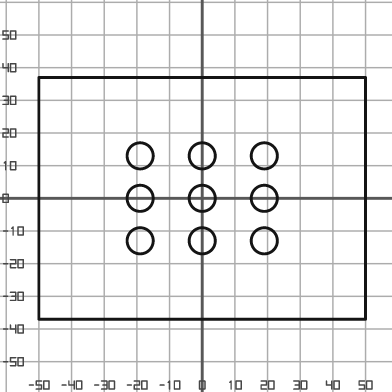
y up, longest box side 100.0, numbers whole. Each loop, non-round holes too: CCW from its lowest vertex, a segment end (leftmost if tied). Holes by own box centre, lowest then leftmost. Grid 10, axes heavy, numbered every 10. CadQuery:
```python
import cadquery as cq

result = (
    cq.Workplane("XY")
    .moveTo(-50.0, -37.0)
    .lineTo(50.0, -37.0)
    .lineTo(50.0, 37.0)
    .lineTo(-50.0, 37.0)
    .close()
    .moveTo(-19.0, -13.0)
    .circle(4.0)
    .moveTo(0.0, -13.0)
    .circle(4.0)
    .moveTo(19.0, -13.0)
    .circle(4.0)
    .moveTo(-19.0, 0.0)
    .circle(4.0)
    .moveTo(0.0, 0.0)
    .circle(4.0)
    .moveTo(19.0, 0.0)
    .circle(4.0)
    .moveTo(-19.0, 13.0)
    .circle(4.0)
    .moveTo(0.0, 13.0)
    .circle(4.0)
    .moveTo(19.0, 13.0)
    .circle(4.0)
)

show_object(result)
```